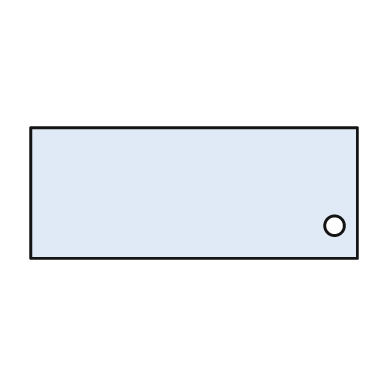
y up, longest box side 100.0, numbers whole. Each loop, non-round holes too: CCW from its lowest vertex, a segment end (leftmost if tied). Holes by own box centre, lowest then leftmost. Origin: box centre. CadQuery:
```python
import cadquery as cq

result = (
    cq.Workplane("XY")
    .moveTo(-50.0, -20.0)
    .lineTo(50.0, -20.0)
    .lineTo(50.0, 20.0)
    .lineTo(-50.0, 20.0)
    .close()
    .moveTo(43.0, -10.0)
    .circle(3.0)
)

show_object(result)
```